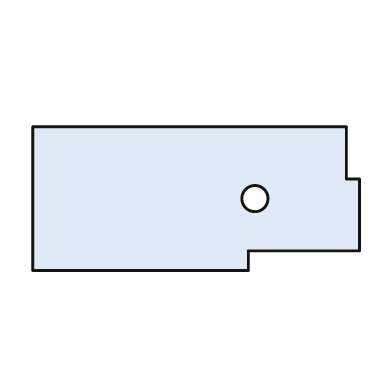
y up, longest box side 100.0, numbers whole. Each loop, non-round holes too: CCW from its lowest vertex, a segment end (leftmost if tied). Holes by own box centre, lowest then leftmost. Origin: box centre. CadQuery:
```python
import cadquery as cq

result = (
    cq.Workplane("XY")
    .moveTo(-50.0, -22.0)
    .lineTo(16.0, -22.0)
    .lineTo(16.0, -16.0)
    .lineTo(50.0, -16.0)
    .lineTo(50.0, 6.0)
    .lineTo(46.0, 6.0)
    .lineTo(46.0, 22.0)
    .lineTo(-50.0, 22.0)
    .close()
    .moveTo(18.0, 0.0)
    .circle(4.0)
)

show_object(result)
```